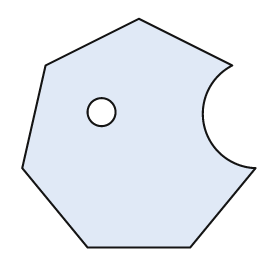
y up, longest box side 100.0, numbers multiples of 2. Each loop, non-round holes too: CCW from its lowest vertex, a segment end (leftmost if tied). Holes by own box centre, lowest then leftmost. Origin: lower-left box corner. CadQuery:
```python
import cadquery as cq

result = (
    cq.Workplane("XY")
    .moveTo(28.0, 0.0)
    .lineTo(72.0, 0.0)
    .lineTo(100.0, 34.0)
    .threePointArc((78.0, 52.0), (90.0, 78.0))
    .lineTo(50.0, 98.0)
    .lineTo(10.0, 78.0)
    .lineTo(0.0, 34.0)
    .close()
    .moveTo(34.0, 58.0)
    .circle(6.0)
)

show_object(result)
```